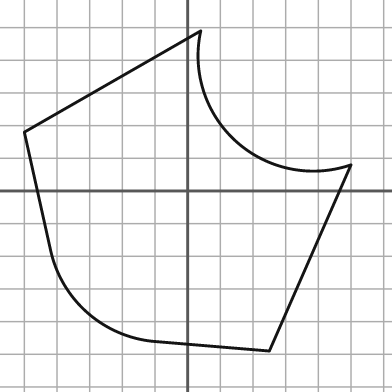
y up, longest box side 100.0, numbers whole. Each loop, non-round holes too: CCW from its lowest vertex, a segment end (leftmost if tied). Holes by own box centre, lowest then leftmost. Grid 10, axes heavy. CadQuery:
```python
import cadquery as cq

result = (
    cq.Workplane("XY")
    .moveTo(25.0, -49.0)
    .lineTo(50.0, 8.0)
    .threePointArc((15.0, 15.0), (4.0, 49.0))
    .lineTo(-50.0, 18.0)
    .lineTo(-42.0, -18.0)
    .threePointArc((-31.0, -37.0), (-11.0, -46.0))
    .close()
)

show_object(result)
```